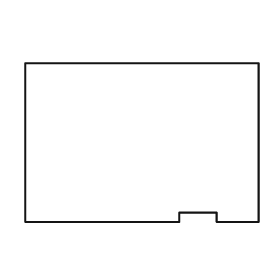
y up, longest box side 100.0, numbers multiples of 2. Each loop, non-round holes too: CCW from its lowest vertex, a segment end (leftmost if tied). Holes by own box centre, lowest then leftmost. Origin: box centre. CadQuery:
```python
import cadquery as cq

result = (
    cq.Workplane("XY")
    .moveTo(-50.0, -34.0)
    .lineTo(16.0, -34.0)
    .lineTo(16.0, -30.0)
    .lineTo(32.0, -30.0)
    .lineTo(32.0, -34.0)
    .lineTo(50.0, -34.0)
    .lineTo(50.0, 34.0)
    .lineTo(-50.0, 34.0)
    .close()
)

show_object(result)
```